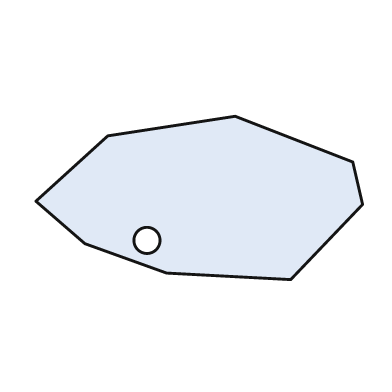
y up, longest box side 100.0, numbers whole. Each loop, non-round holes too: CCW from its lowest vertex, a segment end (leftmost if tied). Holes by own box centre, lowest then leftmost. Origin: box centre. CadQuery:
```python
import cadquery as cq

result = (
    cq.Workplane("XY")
    .moveTo(28.0, -25.0)
    .lineTo(50.0, -2.0)
    .lineTo(47.0, 11.0)
    .lineTo(11.0, 25.0)
    .lineTo(-28.0, 19.0)
    .lineTo(-50.0, -1.0)
    .lineTo(-35.0, -14.0)
    .lineTo(-10.0, -23.0)
    .close()
    .moveTo(-16.0, -13.0)
    .circle(4.0)
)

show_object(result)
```